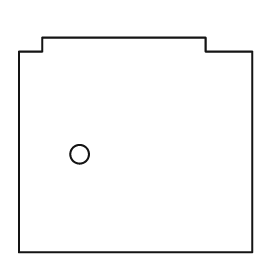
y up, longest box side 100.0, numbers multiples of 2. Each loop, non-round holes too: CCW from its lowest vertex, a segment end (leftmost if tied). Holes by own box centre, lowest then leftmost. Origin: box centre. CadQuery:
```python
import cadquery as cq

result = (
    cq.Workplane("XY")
    .moveTo(-50.0, -46.0)
    .lineTo(50.0, -46.0)
    .lineTo(50.0, 40.0)
    .lineTo(30.0, 40.0)
    .lineTo(30.0, 46.0)
    .lineTo(-40.0, 46.0)
    .lineTo(-40.0, 40.0)
    .lineTo(-50.0, 40.0)
    .close()
    .moveTo(-24.0, -4.0)
    .circle(4.0)
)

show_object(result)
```